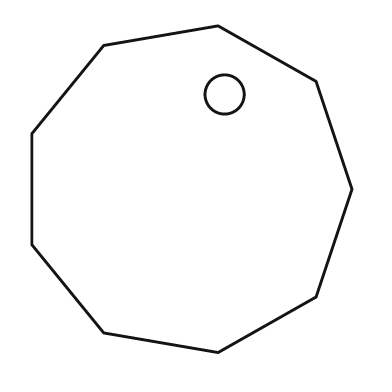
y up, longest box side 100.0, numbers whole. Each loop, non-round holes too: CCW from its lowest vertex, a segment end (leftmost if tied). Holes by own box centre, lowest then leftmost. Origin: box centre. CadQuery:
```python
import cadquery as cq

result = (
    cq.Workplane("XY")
    .moveTo(8.0, -50.0)
    .lineTo(38.0, -33.0)
    .lineTo(49.0, 0.0)
    .lineTo(38.0, 33.0)
    .lineTo(8.0, 50.0)
    .lineTo(-27.0, 44.0)
    .lineTo(-49.0, 17.0)
    .lineTo(-49.0, -17.0)
    .lineTo(-27.0, -44.0)
    .close()
    .moveTo(10.0, 29.0)
    .circle(6.0)
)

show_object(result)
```